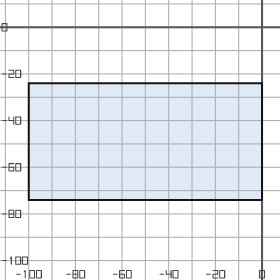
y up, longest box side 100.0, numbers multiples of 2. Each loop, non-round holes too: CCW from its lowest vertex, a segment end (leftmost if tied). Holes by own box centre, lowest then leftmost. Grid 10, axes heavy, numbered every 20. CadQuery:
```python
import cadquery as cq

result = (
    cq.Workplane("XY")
    .moveTo(-100.0, -74.0)
    .lineTo(0.0, -74.0)
    .lineTo(0.0, -24.0)
    .lineTo(-100.0, -24.0)
    .close()
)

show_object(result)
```